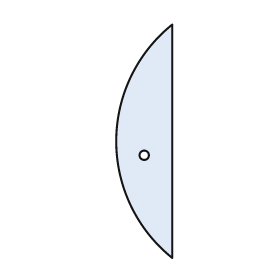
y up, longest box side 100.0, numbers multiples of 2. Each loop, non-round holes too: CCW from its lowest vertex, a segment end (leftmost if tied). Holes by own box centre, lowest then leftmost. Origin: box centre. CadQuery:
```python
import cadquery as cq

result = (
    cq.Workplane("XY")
    .moveTo(12.0, -50.0)
    .lineTo(12.0, 50.0)
    .threePointArc((-12.0, 0.0), (12.0, -50.0))
    .close()
    .moveTo(0.0, -6.0)
    .circle(2.0)
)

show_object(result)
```